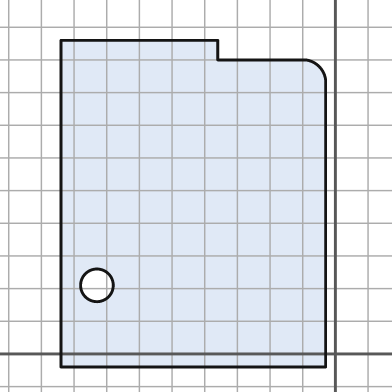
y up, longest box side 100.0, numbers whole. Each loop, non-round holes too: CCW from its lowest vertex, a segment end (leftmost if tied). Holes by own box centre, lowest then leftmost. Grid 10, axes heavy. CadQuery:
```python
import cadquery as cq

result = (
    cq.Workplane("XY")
    .moveTo(-84.0, -4.0)
    .lineTo(-3.0, -4.0)
    .lineTo(-3.0, 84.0)
    .threePointArc((-5.0, 88.0), (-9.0, 90.0))
    .lineTo(-36.0, 90.0)
    .lineTo(-36.0, 96.0)
    .lineTo(-84.0, 96.0)
    .close()
    .moveTo(-73.0, 21.0)
    .circle(5.0)
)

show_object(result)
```